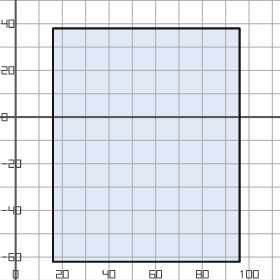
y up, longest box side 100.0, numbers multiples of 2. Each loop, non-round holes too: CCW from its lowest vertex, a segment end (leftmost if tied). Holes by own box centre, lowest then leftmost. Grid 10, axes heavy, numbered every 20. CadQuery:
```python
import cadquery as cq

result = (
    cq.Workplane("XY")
    .moveTo(16.0, -62.0)
    .lineTo(96.0, -62.0)
    .lineTo(96.0, 38.0)
    .lineTo(16.0, 38.0)
    .close()
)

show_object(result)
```